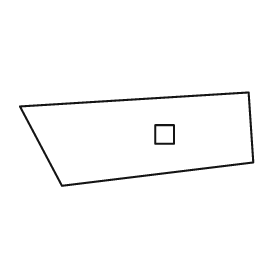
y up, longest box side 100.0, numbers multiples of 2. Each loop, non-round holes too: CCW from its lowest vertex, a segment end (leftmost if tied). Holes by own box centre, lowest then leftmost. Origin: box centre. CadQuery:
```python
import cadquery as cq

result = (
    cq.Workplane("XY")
    .moveTo(-32.0, -20.0)
    .lineTo(50.0, -10.0)
    .lineTo(48.0, 20.0)
    .lineTo(-50.0, 14.0)
    .close()
    .moveTo(8.0, -2.0)
    .lineTo(16.0, -2.0)
    .lineTo(16.0, 6.0)
    .lineTo(8.0, 6.0)
    .close()
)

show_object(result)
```